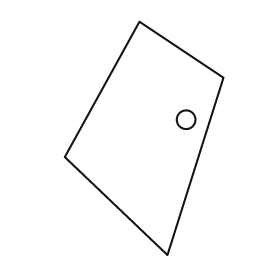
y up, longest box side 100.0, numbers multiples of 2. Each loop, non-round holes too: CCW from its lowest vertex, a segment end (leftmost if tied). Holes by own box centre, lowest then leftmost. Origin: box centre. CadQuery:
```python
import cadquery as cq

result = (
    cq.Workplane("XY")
    .moveTo(10.0, -50.0)
    .lineTo(34.0, 26.0)
    .lineTo(-2.0, 50.0)
    .lineTo(-34.0, -8.0)
    .close()
    .moveTo(18.0, 8.0)
    .circle(4.0)
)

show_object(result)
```